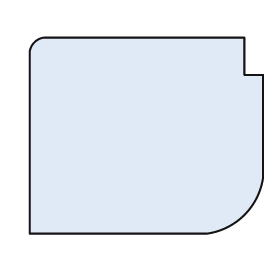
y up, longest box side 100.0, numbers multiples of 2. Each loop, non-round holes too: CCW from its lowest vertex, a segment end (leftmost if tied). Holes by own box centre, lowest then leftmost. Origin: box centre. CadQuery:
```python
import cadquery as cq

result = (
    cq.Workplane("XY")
    .moveTo(-50.0, -42.0)
    .lineTo(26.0, -42.0)
    .threePointArc((42.0, -34.0), (50.0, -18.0))
    .lineTo(50.0, 26.0)
    .lineTo(42.0, 26.0)
    .lineTo(42.0, 42.0)
    .lineTo(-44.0, 42.0)
    .threePointArc((-48.0, 40.0), (-50.0, 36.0))
    .close()
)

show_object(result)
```